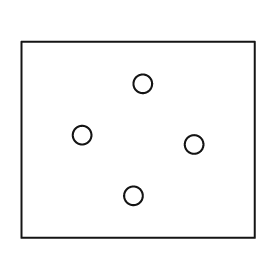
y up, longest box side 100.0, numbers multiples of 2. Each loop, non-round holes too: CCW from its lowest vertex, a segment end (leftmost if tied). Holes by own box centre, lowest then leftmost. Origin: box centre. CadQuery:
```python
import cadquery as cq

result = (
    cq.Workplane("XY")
    .moveTo(-50.0, -42.0)
    .lineTo(50.0, -42.0)
    .lineTo(50.0, 42.0)
    .lineTo(-50.0, 42.0)
    .close()
    .moveTo(-2.0, -24.0)
    .circle(4.0)
    .moveTo(24.0, -2.0)
    .circle(4.0)
    .moveTo(-24.0, 2.0)
    .circle(4.0)
    .moveTo(2.0, 24.0)
    .circle(4.0)
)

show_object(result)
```